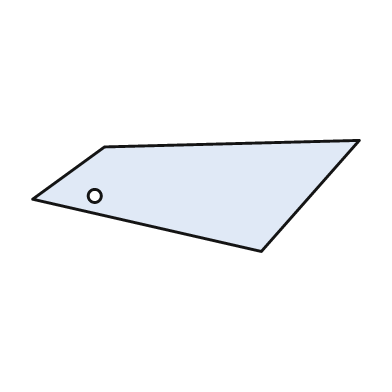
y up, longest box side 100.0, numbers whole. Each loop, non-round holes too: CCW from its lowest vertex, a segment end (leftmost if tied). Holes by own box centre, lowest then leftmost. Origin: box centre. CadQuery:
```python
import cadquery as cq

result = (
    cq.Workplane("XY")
    .moveTo(20.0, -17.0)
    .lineTo(50.0, 17.0)
    .lineTo(-28.0, 15.0)
    .lineTo(-50.0, -1.0)
    .close()
    .moveTo(-31.0, 0.0)
    .circle(2.0)
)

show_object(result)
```